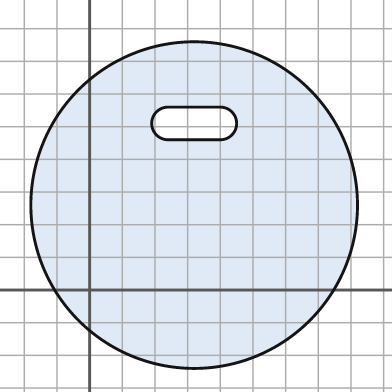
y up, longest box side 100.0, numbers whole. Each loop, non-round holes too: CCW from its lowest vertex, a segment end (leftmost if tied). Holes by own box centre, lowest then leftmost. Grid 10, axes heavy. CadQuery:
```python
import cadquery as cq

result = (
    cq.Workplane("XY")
    .moveTo(32.0, 26.0)
    .circle(50.0)
    .moveTo(24.0, 46.0)
    .lineTo(40.0, 46.0)
    .threePointArc((45.0, 51.0), (40.0, 56.0))
    .lineTo(24.0, 56.0)
    .threePointArc((19.0, 51.0), (24.0, 46.0))
    .close()
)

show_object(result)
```